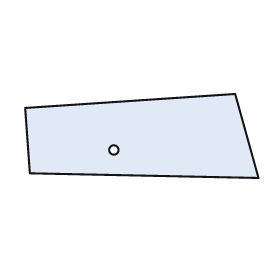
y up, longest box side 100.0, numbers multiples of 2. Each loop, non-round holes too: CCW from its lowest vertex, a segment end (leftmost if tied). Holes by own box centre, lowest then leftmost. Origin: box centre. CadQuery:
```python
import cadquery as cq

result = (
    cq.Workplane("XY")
    .moveTo(50.0, -18.0)
    .lineTo(40.0, 18.0)
    .lineTo(-50.0, 12.0)
    .lineTo(-48.0, -16.0)
    .close()
    .moveTo(-12.0, -6.0)
    .circle(2.0)
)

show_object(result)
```